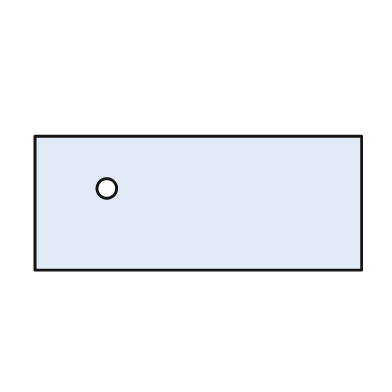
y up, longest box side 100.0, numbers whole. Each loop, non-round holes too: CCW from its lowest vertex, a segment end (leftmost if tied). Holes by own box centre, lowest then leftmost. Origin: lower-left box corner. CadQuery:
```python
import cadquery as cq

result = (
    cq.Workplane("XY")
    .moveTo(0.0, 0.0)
    .lineTo(100.0, 0.0)
    .lineTo(100.0, 41.0)
    .lineTo(0.0, 41.0)
    .close()
    .moveTo(22.0, 25.0)
    .circle(3.0)
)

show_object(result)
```